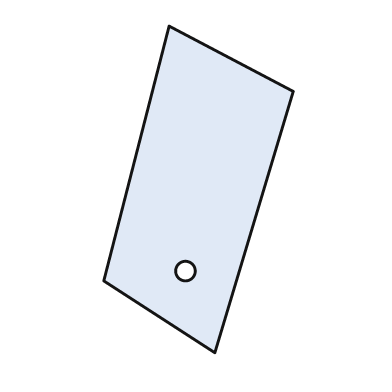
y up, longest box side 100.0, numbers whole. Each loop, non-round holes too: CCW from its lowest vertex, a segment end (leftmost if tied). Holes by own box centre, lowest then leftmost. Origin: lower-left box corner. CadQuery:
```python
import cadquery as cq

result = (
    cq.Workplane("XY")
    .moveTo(34.0, 0.0)
    .lineTo(58.0, 80.0)
    .lineTo(20.0, 100.0)
    .lineTo(0.0, 22.0)
    .close()
    .moveTo(25.0, 25.0)
    .circle(3.0)
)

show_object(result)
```